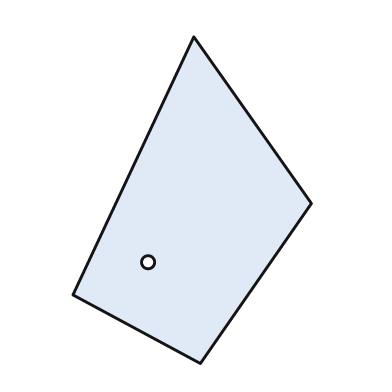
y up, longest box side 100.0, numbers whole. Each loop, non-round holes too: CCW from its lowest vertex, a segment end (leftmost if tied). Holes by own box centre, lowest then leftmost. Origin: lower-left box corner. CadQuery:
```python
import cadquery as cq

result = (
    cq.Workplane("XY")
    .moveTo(39.0, 0.0)
    .lineTo(73.0, 49.0)
    .lineTo(37.0, 100.0)
    .lineTo(0.0, 21.0)
    .close()
    .moveTo(23.0, 31.0)
    .circle(2.0)
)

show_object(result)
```